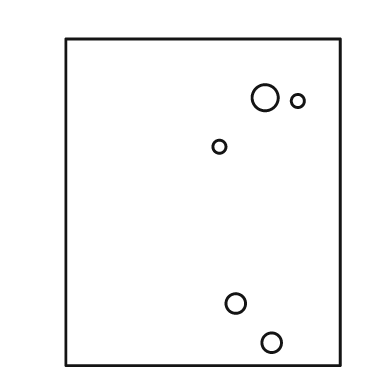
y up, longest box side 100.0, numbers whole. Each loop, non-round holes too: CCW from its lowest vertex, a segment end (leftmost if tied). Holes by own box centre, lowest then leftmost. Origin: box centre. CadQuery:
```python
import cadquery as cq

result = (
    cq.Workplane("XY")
    .moveTo(-42.0, -50.0)
    .lineTo(42.0, -50.0)
    .lineTo(42.0, 50.0)
    .lineTo(-42.0, 50.0)
    .close()
    .moveTo(21.0, -43.0)
    .circle(3.0)
    .moveTo(10.0, -31.0)
    .circle(3.0)
    .moveTo(5.0, 17.0)
    .circle(2.0)
    .moveTo(29.0, 31.0)
    .circle(2.0)
    .moveTo(19.0, 32.0)
    .circle(4.0)
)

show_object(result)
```